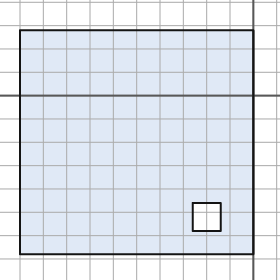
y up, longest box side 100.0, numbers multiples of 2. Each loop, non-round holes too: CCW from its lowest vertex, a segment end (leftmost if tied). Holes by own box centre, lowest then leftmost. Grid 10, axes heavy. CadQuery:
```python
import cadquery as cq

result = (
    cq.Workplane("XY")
    .moveTo(-100.0, -68.0)
    .lineTo(0.0, -68.0)
    .lineTo(0.0, 28.0)
    .lineTo(-100.0, 28.0)
    .close()
    .moveTo(-26.0, -58.0)
    .lineTo(-14.0, -58.0)
    .lineTo(-14.0, -46.0)
    .lineTo(-26.0, -46.0)
    .close()
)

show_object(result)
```